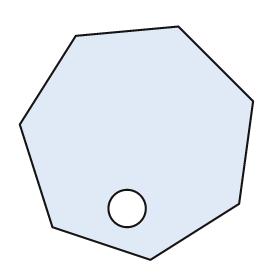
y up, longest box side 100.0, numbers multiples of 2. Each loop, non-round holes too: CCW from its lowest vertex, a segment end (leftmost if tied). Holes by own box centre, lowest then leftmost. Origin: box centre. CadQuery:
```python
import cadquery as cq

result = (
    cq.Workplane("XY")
    .moveTo(6.0, -50.0)
    .lineTo(44.0, -26.0)
    .lineTo(50.0, 18.0)
    .lineTo(18.0, 50.0)
    .lineTo(-26.0, 46.0)
    .lineTo(-50.0, 8.0)
    .lineTo(-36.0, -36.0)
    .close()
    .moveTo(-4.0, -28.0)
    .circle(8.0)
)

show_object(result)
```